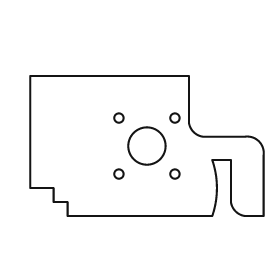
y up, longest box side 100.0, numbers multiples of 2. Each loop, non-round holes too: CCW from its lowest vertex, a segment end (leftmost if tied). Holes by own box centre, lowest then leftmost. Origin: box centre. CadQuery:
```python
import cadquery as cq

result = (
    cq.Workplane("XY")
    .moveTo(-34.0, -30.0)
    .lineTo(28.0, -30.0)
    .threePointArc((30.0, -18.0), (28.0, -6.0))
    .lineTo(36.0, -6.0)
    .lineTo(36.0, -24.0)
    .threePointArc((38.0, -28.0), (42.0, -30.0))
    .lineTo(50.0, -30.0)
    .lineTo(50.0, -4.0)
    .threePointArc((48.0, 2.0), (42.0, 4.0))
    .lineTo(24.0, 4.0)
    .threePointArc((20.0, 6.0), (18.0, 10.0))
    .lineTo(18.0, 30.0)
    .lineTo(-50.0, 30.0)
    .lineTo(-50.0, -18.0)
    .lineTo(-40.0, -18.0)
    .lineTo(-40.0, -24.0)
    .lineTo(-34.0, -24.0)
    .close()
    .moveTo(-12.0, -12.0)
    .circle(2.0)
    .moveTo(12.0, -12.0)
    .circle(2.0)
    .moveTo(0.0, 0.0)
    .circle(8.0)
    .moveTo(-12.0, 12.0)
    .circle(2.0)
    .moveTo(12.0, 12.0)
    .circle(2.0)
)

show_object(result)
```